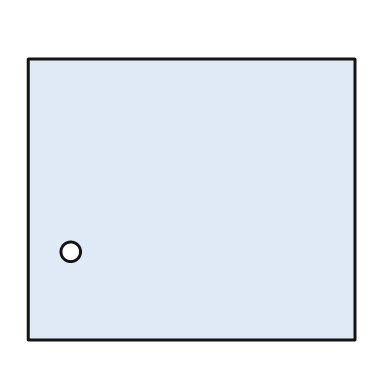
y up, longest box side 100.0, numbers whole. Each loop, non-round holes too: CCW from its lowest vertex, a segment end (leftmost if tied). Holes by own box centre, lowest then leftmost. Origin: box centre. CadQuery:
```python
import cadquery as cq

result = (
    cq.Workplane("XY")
    .moveTo(-50.0, -43.0)
    .lineTo(50.0, -43.0)
    .lineTo(50.0, 43.0)
    .lineTo(-50.0, 43.0)
    .close()
    .moveTo(-37.0, -16.0)
    .circle(3.0)
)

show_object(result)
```